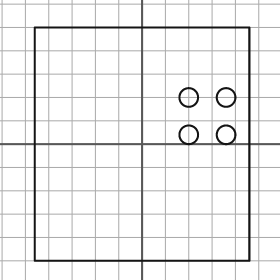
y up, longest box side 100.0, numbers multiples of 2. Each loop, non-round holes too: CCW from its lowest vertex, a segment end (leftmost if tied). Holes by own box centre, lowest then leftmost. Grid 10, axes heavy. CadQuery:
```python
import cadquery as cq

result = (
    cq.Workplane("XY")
    .moveTo(-46.0, -50.0)
    .lineTo(46.0, -50.0)
    .lineTo(46.0, 50.0)
    .lineTo(-46.0, 50.0)
    .close()
    .moveTo(20.0, 4.0)
    .circle(4.0)
    .moveTo(36.0, 4.0)
    .circle(4.0)
    .moveTo(20.0, 20.0)
    .circle(4.0)
    .moveTo(36.0, 20.0)
    .circle(4.0)
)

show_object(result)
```